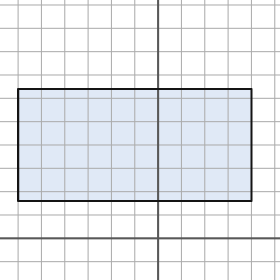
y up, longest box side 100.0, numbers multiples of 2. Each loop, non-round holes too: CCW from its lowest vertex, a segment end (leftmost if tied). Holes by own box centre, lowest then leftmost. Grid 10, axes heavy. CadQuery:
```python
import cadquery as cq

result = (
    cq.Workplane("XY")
    .moveTo(-60.0, 16.0)
    .lineTo(40.0, 16.0)
    .lineTo(40.0, 64.0)
    .lineTo(-60.0, 64.0)
    .close()
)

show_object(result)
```